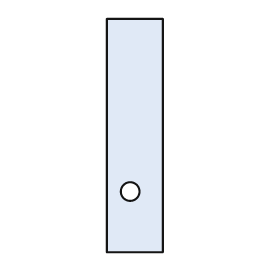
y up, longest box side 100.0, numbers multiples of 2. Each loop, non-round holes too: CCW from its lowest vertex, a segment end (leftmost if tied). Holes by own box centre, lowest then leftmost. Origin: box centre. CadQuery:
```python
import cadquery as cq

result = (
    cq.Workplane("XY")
    .moveTo(-12.0, -50.0)
    .lineTo(12.0, -50.0)
    .lineTo(12.0, 50.0)
    .lineTo(-12.0, 50.0)
    .close()
    .moveTo(-2.0, -24.0)
    .circle(4.0)
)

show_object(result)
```